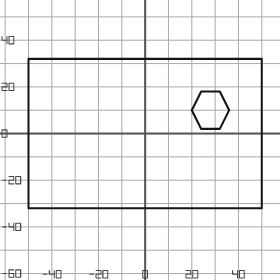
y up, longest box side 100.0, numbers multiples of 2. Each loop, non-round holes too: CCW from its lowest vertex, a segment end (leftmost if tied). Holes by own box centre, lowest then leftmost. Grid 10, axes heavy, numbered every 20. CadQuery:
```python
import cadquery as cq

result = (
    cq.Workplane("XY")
    .moveTo(-50.0, -32.0)
    .lineTo(50.0, -32.0)
    .lineTo(50.0, 32.0)
    .lineTo(-50.0, 32.0)
    .close()
    .moveTo(24.0, 2.0)
    .lineTo(32.0, 2.0)
    .lineTo(36.0, 10.0)
    .lineTo(32.0, 18.0)
    .lineTo(24.0, 18.0)
    .lineTo(20.0, 10.0)
    .close()
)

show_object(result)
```